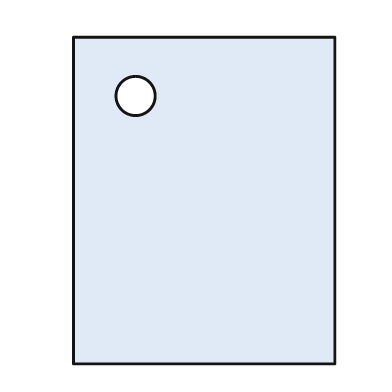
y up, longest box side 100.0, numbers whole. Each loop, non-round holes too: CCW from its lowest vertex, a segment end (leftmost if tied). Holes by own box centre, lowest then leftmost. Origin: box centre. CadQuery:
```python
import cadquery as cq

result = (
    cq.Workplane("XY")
    .moveTo(-40.0, -50.0)
    .lineTo(40.0, -50.0)
    .lineTo(40.0, 50.0)
    .lineTo(-40.0, 50.0)
    .close()
    .moveTo(-21.0, 32.0)
    .circle(6.0)
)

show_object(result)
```